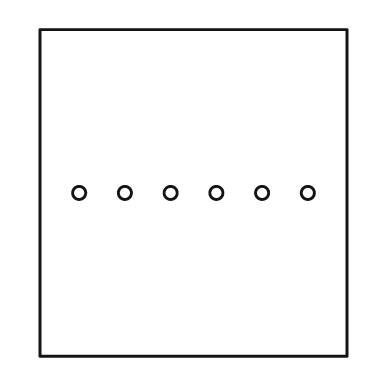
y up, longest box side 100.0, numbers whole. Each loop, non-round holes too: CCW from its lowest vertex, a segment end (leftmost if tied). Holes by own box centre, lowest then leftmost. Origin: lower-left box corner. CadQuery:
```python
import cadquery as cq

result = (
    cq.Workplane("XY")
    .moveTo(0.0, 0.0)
    .lineTo(94.0, 0.0)
    .lineTo(94.0, 100.0)
    .lineTo(0.0, 100.0)
    .close()
    .moveTo(12.0, 50.0)
    .circle(2.0)
    .moveTo(26.0, 50.0)
    .circle(2.0)
    .moveTo(40.0, 50.0)
    .circle(2.0)
    .moveTo(54.0, 50.0)
    .circle(2.0)
    .moveTo(68.0, 50.0)
    .circle(2.0)
    .moveTo(82.0, 50.0)
    .circle(2.0)
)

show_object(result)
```